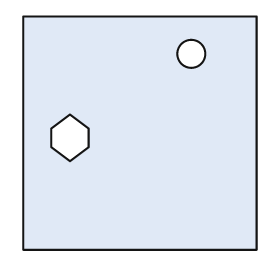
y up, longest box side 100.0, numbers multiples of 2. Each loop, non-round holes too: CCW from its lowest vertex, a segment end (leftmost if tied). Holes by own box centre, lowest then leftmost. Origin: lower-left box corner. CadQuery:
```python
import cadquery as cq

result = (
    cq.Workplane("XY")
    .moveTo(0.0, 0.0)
    .lineTo(100.0, 0.0)
    .lineTo(100.0, 100.0)
    .lineTo(0.0, 100.0)
    .close()
    .moveTo(20.0, 38.0)
    .lineTo(28.0, 44.0)
    .lineTo(28.0, 52.0)
    .lineTo(20.0, 58.0)
    .lineTo(12.0, 52.0)
    .lineTo(12.0, 44.0)
    .close()
    .moveTo(72.0, 84.0)
    .circle(6.0)
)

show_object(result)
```